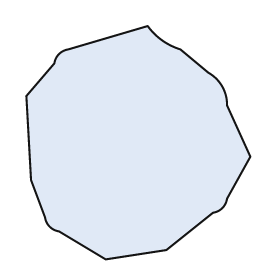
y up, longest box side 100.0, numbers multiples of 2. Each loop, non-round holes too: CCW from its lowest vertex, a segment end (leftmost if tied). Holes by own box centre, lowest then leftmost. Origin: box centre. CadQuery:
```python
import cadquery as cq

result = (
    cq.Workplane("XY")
    .moveTo(-14.0, -50.0)
    .lineTo(12.0, -46.0)
    .lineTo(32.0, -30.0)
    .threePointArc((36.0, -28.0), (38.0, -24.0))
    .lineTo(48.0, -6.0)
    .lineTo(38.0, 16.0)
    .threePointArc((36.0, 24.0), (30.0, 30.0))
    .lineTo(18.0, 40.0)
    .threePointArc((10.0, 44.0), (4.0, 50.0))
    .lineTo(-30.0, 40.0)
    .threePointArc((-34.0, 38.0), (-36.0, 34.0))
    .lineTo(-48.0, 20.0)
    .lineTo(-46.0, -16.0)
    .lineTo(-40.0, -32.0)
    .threePointArc((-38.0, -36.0), (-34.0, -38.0))
    .close()
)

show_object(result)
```